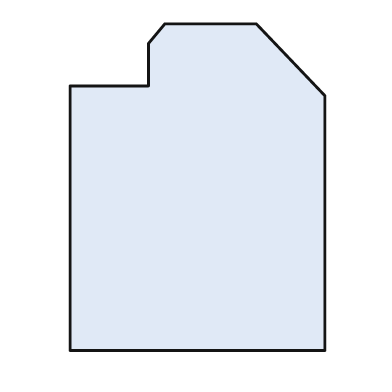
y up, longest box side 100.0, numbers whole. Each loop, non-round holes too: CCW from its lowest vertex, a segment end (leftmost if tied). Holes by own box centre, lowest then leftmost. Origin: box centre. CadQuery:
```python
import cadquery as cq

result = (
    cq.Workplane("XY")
    .moveTo(-39.0, -50.0)
    .lineTo(39.0, -50.0)
    .lineTo(39.0, 28.0)
    .lineTo(18.0, 50.0)
    .lineTo(-10.0, 50.0)
    .lineTo(-15.0, 44.0)
    .lineTo(-15.0, 31.0)
    .lineTo(-39.0, 31.0)
    .close()
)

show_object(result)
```